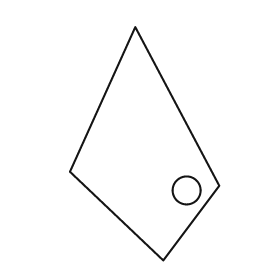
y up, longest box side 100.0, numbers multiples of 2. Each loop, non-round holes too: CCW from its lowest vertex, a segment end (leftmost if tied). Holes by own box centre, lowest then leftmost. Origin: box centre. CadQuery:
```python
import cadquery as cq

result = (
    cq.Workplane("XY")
    .moveTo(8.0, -50.0)
    .lineTo(32.0, -18.0)
    .lineTo(-4.0, 50.0)
    .lineTo(-32.0, -12.0)
    .close()
    .moveTo(18.0, -20.0)
    .circle(6.0)
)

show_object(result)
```